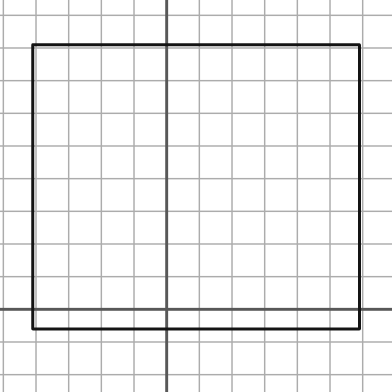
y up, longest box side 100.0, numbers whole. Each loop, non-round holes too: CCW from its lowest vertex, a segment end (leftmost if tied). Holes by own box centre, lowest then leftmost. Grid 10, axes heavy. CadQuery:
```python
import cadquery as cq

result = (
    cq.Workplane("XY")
    .moveTo(-41.0, -6.0)
    .lineTo(59.0, -6.0)
    .lineTo(59.0, 81.0)
    .lineTo(-41.0, 81.0)
    .close()
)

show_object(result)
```